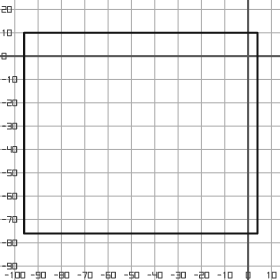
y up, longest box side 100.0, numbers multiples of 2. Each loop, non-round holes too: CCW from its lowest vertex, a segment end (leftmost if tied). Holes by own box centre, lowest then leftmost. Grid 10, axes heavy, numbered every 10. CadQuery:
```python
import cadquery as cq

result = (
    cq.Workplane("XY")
    .moveTo(-96.0, -76.0)
    .lineTo(4.0, -76.0)
    .lineTo(4.0, 10.0)
    .lineTo(-96.0, 10.0)
    .close()
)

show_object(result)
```